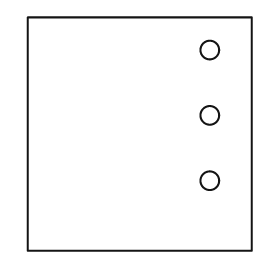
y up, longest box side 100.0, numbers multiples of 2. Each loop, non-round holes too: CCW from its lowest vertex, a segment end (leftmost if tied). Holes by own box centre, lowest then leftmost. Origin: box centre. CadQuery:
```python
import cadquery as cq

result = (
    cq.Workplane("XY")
    .moveTo(-48.0, -50.0)
    .lineTo(48.0, -50.0)
    .lineTo(48.0, 50.0)
    .lineTo(-48.0, 50.0)
    .close()
    .moveTo(30.0, -20.0)
    .circle(4.0)
    .moveTo(30.0, 8.0)
    .circle(4.0)
    .moveTo(30.0, 36.0)
    .circle(4.0)
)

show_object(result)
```